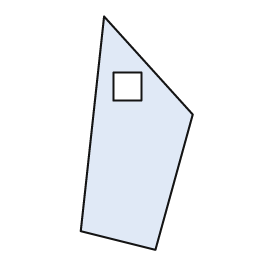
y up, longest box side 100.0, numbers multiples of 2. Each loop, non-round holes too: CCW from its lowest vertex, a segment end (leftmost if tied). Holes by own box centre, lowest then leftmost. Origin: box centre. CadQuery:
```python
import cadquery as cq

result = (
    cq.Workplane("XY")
    .moveTo(8.0, -50.0)
    .lineTo(24.0, 8.0)
    .lineTo(-14.0, 50.0)
    .lineTo(-24.0, -42.0)
    .close()
    .moveTo(-10.0, 14.0)
    .lineTo(2.0, 14.0)
    .lineTo(2.0, 26.0)
    .lineTo(-10.0, 26.0)
    .close()
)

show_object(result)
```